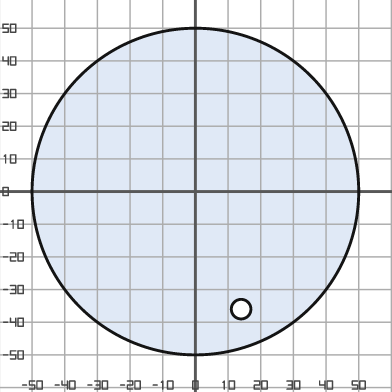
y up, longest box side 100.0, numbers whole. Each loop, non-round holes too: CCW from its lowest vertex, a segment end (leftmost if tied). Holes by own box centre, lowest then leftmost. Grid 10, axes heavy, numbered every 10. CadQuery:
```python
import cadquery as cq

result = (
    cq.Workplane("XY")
    .moveTo(0.0, 0.0)
    .circle(50.0)
    .moveTo(14.0, -36.0)
    .circle(3.0)
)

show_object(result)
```